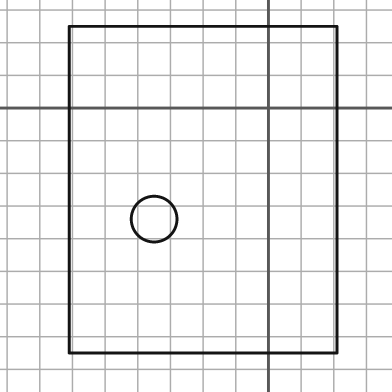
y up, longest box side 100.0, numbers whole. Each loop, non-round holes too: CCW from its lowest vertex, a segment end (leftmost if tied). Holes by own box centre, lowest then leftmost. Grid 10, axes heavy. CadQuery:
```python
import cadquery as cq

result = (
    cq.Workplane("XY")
    .moveTo(-61.0, -75.0)
    .lineTo(21.0, -75.0)
    .lineTo(21.0, 25.0)
    .lineTo(-61.0, 25.0)
    .close()
    .moveTo(-35.0, -34.0)
    .circle(7.0)
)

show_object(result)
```